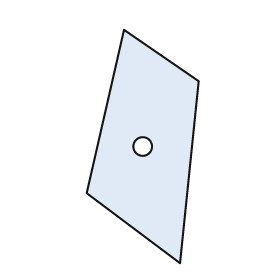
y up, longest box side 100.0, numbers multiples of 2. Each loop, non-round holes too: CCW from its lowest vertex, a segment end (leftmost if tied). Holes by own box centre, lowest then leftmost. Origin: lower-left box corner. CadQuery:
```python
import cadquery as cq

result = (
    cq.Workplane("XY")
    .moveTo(40.0, 0.0)
    .lineTo(48.0, 78.0)
    .lineTo(16.0, 100.0)
    .lineTo(0.0, 30.0)
    .close()
    .moveTo(24.0, 50.0)
    .circle(4.0)
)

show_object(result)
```